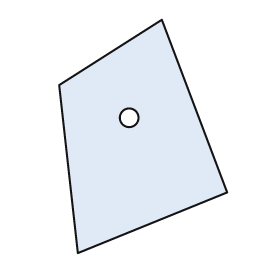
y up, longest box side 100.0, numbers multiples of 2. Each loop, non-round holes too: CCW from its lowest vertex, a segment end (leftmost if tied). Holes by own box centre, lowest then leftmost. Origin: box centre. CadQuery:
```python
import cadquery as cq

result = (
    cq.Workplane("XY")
    .moveTo(-28.0, -50.0)
    .lineTo(36.0, -24.0)
    .lineTo(8.0, 50.0)
    .lineTo(-36.0, 22.0)
    .close()
    .moveTo(-6.0, 8.0)
    .circle(4.0)
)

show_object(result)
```